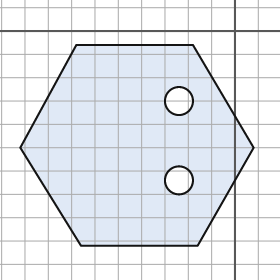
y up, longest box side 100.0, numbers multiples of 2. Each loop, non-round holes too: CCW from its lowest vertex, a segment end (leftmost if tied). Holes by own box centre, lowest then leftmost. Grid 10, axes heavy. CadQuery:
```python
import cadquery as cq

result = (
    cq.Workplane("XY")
    .moveTo(-66.0, -92.0)
    .lineTo(-16.0, -92.0)
    .lineTo(8.0, -50.0)
    .lineTo(-18.0, -6.0)
    .lineTo(-68.0, -6.0)
    .lineTo(-92.0, -50.0)
    .close()
    .moveTo(-24.0, -64.0)
    .circle(6.0)
    .moveTo(-24.0, -30.0)
    .circle(6.0)
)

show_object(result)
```